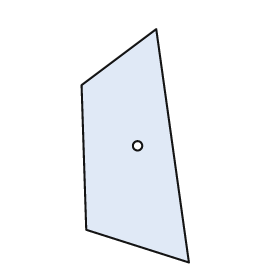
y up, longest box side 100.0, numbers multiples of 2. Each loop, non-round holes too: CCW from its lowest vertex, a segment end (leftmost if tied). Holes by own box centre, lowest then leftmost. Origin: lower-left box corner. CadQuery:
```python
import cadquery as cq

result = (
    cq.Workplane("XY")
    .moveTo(46.0, 0.0)
    .lineTo(32.0, 100.0)
    .lineTo(0.0, 76.0)
    .lineTo(2.0, 14.0)
    .close()
    .moveTo(24.0, 50.0)
    .circle(2.0)
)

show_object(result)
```